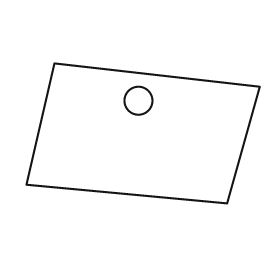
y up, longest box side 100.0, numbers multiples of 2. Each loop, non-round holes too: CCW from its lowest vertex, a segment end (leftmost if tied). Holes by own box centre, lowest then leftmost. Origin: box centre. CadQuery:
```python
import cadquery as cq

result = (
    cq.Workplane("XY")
    .moveTo(36.0, -30.0)
    .lineTo(50.0, 20.0)
    .lineTo(-38.0, 30.0)
    .lineTo(-50.0, -22.0)
    .close()
    .moveTo(-2.0, 14.0)
    .circle(6.0)
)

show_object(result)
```